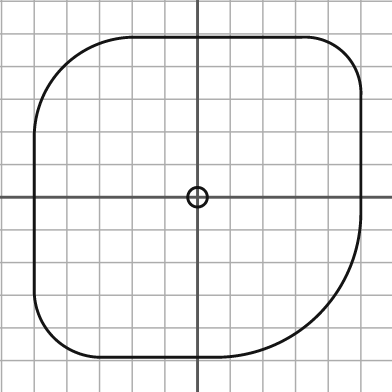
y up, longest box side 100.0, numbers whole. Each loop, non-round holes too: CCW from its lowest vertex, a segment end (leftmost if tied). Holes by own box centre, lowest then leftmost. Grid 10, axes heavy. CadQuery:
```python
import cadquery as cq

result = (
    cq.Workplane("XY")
    .moveTo(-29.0, -49.0)
    .lineTo(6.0, -49.0)
    .threePointArc((37.0, -36.0), (50.0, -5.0))
    .lineTo(50.0, 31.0)
    .threePointArc((45.0, 44.0), (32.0, 49.0))
    .lineTo(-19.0, 49.0)
    .threePointArc((-41.0, 40.0), (-50.0, 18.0))
    .lineTo(-50.0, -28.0)
    .threePointArc((-44.0, -43.0), (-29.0, -49.0))
    .close()
    .moveTo(0.0, 0.0)
    .circle(3.0)
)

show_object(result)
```